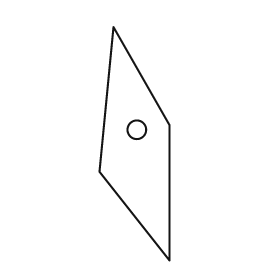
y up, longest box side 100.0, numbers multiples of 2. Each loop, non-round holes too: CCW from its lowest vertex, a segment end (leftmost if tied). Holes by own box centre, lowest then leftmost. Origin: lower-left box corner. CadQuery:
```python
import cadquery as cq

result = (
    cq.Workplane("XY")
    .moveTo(30.0, 0.0)
    .lineTo(30.0, 58.0)
    .lineTo(6.0, 100.0)
    .lineTo(0.0, 38.0)
    .close()
    .moveTo(16.0, 56.0)
    .circle(4.0)
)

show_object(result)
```